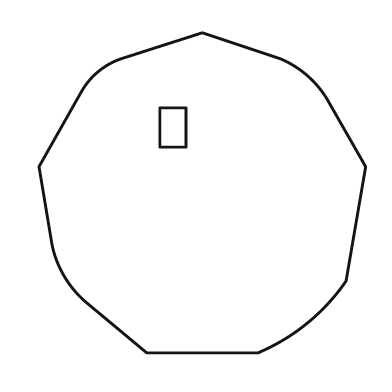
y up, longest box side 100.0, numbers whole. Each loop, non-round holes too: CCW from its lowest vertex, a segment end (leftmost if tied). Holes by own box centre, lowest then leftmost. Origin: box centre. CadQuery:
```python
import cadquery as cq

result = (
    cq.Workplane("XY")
    .moveTo(-17.0, -49.0)
    .lineTo(17.0, -49.0)
    .threePointArc((32.0, -40.0), (44.0, -27.0))
    .lineTo(50.0, 8.0)
    .lineTo(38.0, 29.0)
    .threePointArc((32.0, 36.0), (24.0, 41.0))
    .lineTo(0.0, 49.0)
    .lineTo(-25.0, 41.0)
    .threePointArc((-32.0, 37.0), (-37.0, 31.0))
    .lineTo(-50.0, 8.0)
    .lineTo(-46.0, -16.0)
    .threePointArc((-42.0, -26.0), (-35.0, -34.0))
    .close()
    .moveTo(-13.0, 14.0)
    .lineTo(-5.0, 14.0)
    .lineTo(-5.0, 26.0)
    .lineTo(-13.0, 26.0)
    .close()
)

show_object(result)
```